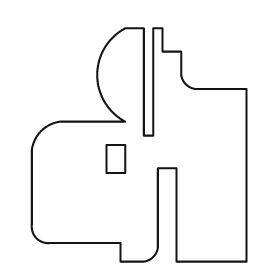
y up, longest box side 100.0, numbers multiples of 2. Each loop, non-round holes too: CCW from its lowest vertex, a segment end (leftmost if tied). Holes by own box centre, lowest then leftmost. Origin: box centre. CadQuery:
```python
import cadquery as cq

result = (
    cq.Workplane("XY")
    .moveTo(-8.0, -50.0)
    .lineTo(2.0, -50.0)
    .threePointArc((6.0, -48.0), (8.0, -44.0))
    .lineTo(8.0, -10.0)
    .lineTo(16.0, -10.0)
    .lineTo(16.0, -50.0)
    .lineTo(46.0, -50.0)
    .lineTo(46.0, 24.0)
    .lineTo(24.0, 24.0)
    .threePointArc((20.0, 26.0), (18.0, 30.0))
    .lineTo(18.0, 40.0)
    .lineTo(10.0, 40.0)
    .lineTo(10.0, 50.0)
    .lineTo(6.0, 50.0)
    .lineTo(6.0, 4.0)
    .lineTo(2.0, 4.0)
    .lineTo(2.0, 50.0)
    .lineTo(-6.0, 50.0)
    .threePointArc((-18.0, 30.0), (-6.0, 10.0))
    .lineTo(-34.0, 10.0)
    .threePointArc((-42.0, 6.0), (-46.0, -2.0))
    .lineTo(-46.0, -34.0)
    .threePointArc((-44.0, -40.0), (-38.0, -42.0))
    .lineTo(-8.0, -42.0)
    .close()
    .moveTo(-14.0, -12.0)
    .lineTo(-6.0, -12.0)
    .lineTo(-6.0, 0.0)
    .lineTo(-14.0, 0.0)
    .close()
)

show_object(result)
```